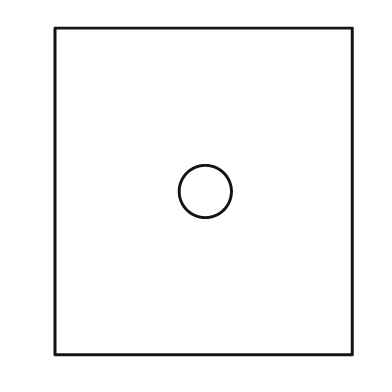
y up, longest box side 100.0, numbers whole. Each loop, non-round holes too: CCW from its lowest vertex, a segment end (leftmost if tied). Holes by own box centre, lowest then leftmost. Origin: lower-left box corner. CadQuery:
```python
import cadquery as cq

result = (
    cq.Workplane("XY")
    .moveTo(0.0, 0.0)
    .lineTo(91.0, 0.0)
    .lineTo(91.0, 100.0)
    .lineTo(0.0, 100.0)
    .close()
    .moveTo(46.0, 50.0)
    .circle(8.0)
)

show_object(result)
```